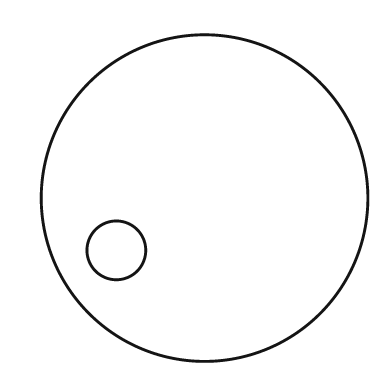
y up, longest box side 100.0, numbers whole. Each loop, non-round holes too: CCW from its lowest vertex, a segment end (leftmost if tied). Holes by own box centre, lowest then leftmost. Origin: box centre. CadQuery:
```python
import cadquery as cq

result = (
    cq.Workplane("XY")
    .moveTo(0.0, 0.0)
    .circle(50.0)
    .moveTo(-27.0, -16.0)
    .circle(9.0)
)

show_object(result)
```